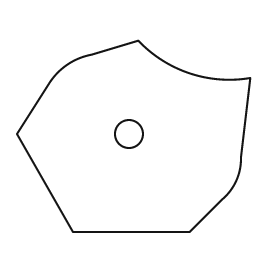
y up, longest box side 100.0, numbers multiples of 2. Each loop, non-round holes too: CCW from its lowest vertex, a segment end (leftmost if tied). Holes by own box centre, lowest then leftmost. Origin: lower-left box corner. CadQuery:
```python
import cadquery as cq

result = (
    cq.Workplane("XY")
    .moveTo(24.0, 0.0)
    .lineTo(74.0, 0.0)
    .lineTo(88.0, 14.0)
    .threePointArc((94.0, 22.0), (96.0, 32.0))
    .lineTo(100.0, 66.0)
    .threePointArc((74.0, 68.0), (52.0, 82.0))
    .lineTo(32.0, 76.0)
    .threePointArc((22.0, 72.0), (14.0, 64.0))
    .lineTo(0.0, 42.0)
    .close()
    .moveTo(48.0, 42.0)
    .circle(6.0)
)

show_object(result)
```